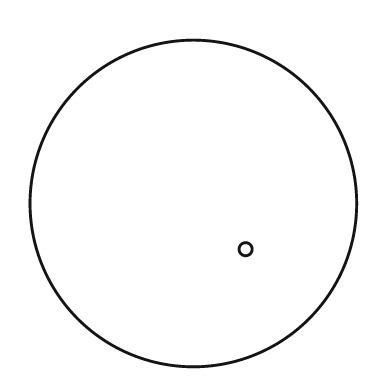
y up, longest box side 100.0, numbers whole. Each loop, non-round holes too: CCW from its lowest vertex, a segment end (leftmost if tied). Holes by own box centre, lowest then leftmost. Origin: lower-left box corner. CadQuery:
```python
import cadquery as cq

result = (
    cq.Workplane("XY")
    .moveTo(50.0, 50.0)
    .circle(50.0)
    .moveTo(66.0, 36.0)
    .circle(2.0)
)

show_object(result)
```